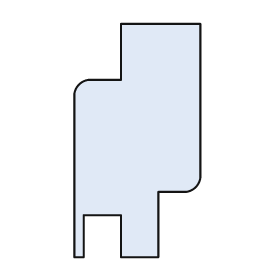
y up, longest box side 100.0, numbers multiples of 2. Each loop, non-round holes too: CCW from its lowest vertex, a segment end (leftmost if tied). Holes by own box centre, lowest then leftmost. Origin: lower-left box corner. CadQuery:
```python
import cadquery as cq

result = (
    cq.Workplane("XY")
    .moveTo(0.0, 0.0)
    .lineTo(4.0, 0.0)
    .lineTo(4.0, 18.0)
    .lineTo(20.0, 18.0)
    .lineTo(20.0, 0.0)
    .lineTo(36.0, 0.0)
    .lineTo(36.0, 28.0)
    .lineTo(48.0, 28.0)
    .threePointArc((52.0, 30.0), (54.0, 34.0))
    .lineTo(54.0, 100.0)
    .lineTo(20.0, 100.0)
    .lineTo(20.0, 76.0)
    .lineTo(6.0, 76.0)
    .threePointArc((2.0, 74.0), (0.0, 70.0))
    .close()
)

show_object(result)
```